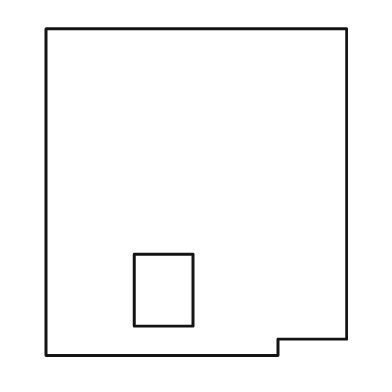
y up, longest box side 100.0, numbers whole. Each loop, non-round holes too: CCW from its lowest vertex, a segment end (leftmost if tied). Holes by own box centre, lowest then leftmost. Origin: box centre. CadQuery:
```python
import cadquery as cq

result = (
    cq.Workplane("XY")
    .moveTo(-46.0, -50.0)
    .lineTo(25.0, -50.0)
    .lineTo(25.0, -45.0)
    .lineTo(46.0, -45.0)
    .lineTo(46.0, 50.0)
    .lineTo(-46.0, 50.0)
    .close()
    .moveTo(-19.0, -41.0)
    .lineTo(-1.0, -41.0)
    .lineTo(-1.0, -19.0)
    .lineTo(-19.0, -19.0)
    .close()
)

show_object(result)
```